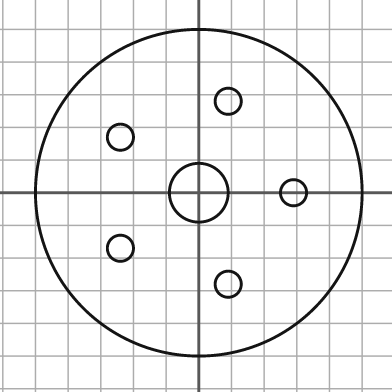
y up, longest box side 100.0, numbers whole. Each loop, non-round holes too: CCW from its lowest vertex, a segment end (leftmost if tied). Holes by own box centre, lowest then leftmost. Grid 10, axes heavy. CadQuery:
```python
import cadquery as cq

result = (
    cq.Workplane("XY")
    .moveTo(0.0, 0.0)
    .circle(50.0)
    .moveTo(9.0, -28.0)
    .circle(4.0)
    .moveTo(-24.0, -17.0)
    .circle(4.0)
    .moveTo(0.0, 0.0)
    .circle(9.0)
    .moveTo(29.0, 0.0)
    .circle(4.0)
    .moveTo(-24.0, 17.0)
    .circle(4.0)
    .moveTo(9.0, 28.0)
    .circle(4.0)
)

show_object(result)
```